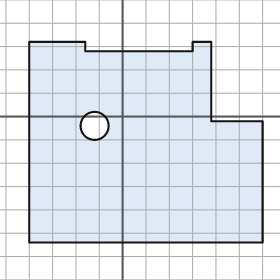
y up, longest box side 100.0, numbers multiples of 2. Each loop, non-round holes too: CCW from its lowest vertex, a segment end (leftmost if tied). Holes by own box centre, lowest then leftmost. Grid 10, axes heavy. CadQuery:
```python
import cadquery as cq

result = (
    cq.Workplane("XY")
    .moveTo(-40.0, -54.0)
    .lineTo(60.0, -54.0)
    .lineTo(60.0, -2.0)
    .lineTo(38.0, -2.0)
    .lineTo(38.0, 32.0)
    .lineTo(30.0, 32.0)
    .lineTo(30.0, 28.0)
    .lineTo(-16.0, 28.0)
    .lineTo(-16.0, 32.0)
    .lineTo(-40.0, 32.0)
    .close()
    .moveTo(-12.0, -4.0)
    .circle(6.0)
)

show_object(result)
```